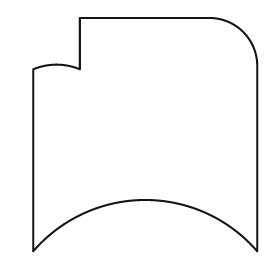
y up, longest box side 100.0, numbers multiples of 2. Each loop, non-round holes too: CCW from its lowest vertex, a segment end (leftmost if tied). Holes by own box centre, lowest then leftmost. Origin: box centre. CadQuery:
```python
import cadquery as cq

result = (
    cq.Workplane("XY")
    .moveTo(-48.0, -50.0)
    .threePointArc((0.0, -28.0), (48.0, -50.0))
    .lineTo(48.0, 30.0)
    .threePointArc((42.0, 44.0), (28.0, 50.0))
    .lineTo(-28.0, 50.0)
    .lineTo(-28.0, 28.0)
    .threePointArc((-38.0, 30.0), (-48.0, 28.0))
    .close()
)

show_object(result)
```